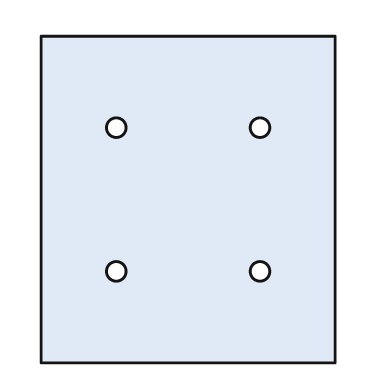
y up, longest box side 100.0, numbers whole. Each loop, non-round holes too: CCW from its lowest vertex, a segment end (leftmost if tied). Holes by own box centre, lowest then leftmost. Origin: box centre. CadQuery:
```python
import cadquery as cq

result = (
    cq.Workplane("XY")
    .moveTo(-45.0, -50.0)
    .lineTo(45.0, -50.0)
    .lineTo(45.0, 50.0)
    .lineTo(-45.0, 50.0)
    .close()
    .moveTo(-22.0, -22.0)
    .circle(3.0)
    .moveTo(22.0, -22.0)
    .circle(3.0)
    .moveTo(-22.0, 22.0)
    .circle(3.0)
    .moveTo(22.0, 22.0)
    .circle(3.0)
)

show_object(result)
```